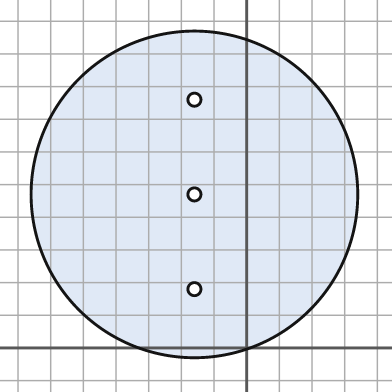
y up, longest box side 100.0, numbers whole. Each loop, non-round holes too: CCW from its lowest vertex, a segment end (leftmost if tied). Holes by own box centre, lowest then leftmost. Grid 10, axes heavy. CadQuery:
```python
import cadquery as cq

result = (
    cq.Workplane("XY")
    .moveTo(-16.0, 47.0)
    .circle(50.0)
    .moveTo(-16.0, 18.0)
    .circle(2.0)
    .moveTo(-16.0, 47.0)
    .circle(2.0)
    .moveTo(-16.0, 76.0)
    .circle(2.0)
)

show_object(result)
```